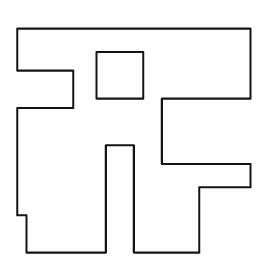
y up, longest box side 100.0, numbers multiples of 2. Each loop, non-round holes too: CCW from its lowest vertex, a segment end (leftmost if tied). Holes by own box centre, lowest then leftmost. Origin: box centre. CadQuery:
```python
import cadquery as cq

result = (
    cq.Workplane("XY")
    .moveTo(-46.0, -48.0)
    .lineTo(-12.0, -48.0)
    .lineTo(-12.0, -2.0)
    .lineTo(0.0, -2.0)
    .lineTo(0.0, -48.0)
    .lineTo(28.0, -48.0)
    .lineTo(28.0, -20.0)
    .lineTo(50.0, -20.0)
    .lineTo(50.0, -10.0)
    .lineTo(12.0, -10.0)
    .lineTo(12.0, 18.0)
    .lineTo(50.0, 18.0)
    .lineTo(50.0, 48.0)
    .lineTo(-50.0, 48.0)
    .lineTo(-50.0, 30.0)
    .lineTo(-26.0, 30.0)
    .lineTo(-26.0, 14.0)
    .lineTo(-50.0, 14.0)
    .lineTo(-50.0, -32.0)
    .lineTo(-46.0, -32.0)
    .close()
    .moveTo(-16.0, 18.0)
    .lineTo(4.0, 18.0)
    .lineTo(4.0, 38.0)
    .lineTo(-16.0, 38.0)
    .close()
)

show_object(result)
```